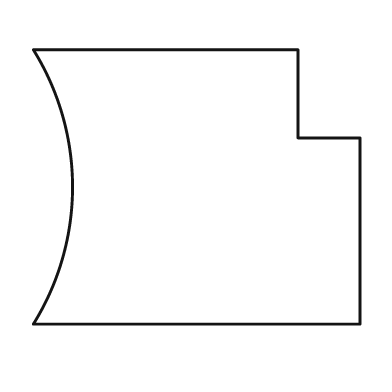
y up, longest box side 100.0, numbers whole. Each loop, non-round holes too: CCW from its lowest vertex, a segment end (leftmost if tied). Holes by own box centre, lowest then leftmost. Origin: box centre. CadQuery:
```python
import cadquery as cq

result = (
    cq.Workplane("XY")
    .moveTo(-50.0, -42.0)
    .lineTo(50.0, -42.0)
    .lineTo(50.0, 15.0)
    .lineTo(31.0, 15.0)
    .lineTo(31.0, 42.0)
    .lineTo(-50.0, 42.0)
    .threePointArc((-38.0, 0.0), (-50.0, -42.0))
    .close()
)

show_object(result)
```